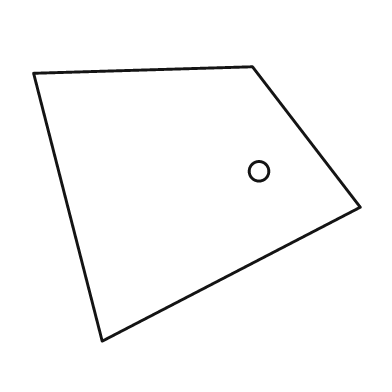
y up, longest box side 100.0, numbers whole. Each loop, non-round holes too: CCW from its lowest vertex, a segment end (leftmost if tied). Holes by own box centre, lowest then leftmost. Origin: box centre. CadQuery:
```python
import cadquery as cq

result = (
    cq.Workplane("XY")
    .moveTo(-29.0, -42.0)
    .lineTo(50.0, -1.0)
    .lineTo(17.0, 42.0)
    .lineTo(-50.0, 40.0)
    .close()
    .moveTo(19.0, 10.0)
    .circle(3.0)
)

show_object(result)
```